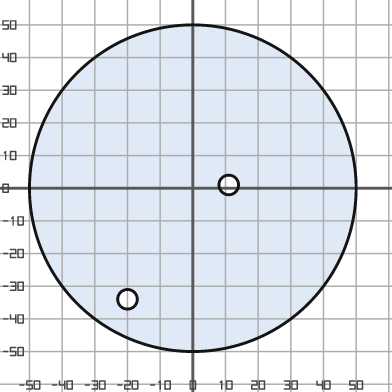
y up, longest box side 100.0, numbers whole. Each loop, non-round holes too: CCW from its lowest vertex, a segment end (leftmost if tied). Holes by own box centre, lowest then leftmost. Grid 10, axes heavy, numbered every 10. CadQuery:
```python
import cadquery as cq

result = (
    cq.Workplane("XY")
    .moveTo(0.0, 0.0)
    .circle(50.0)
    .moveTo(-20.0, -34.0)
    .circle(3.0)
    .moveTo(11.0, 1.0)
    .circle(3.0)
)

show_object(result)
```